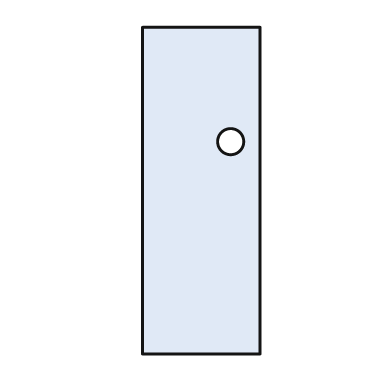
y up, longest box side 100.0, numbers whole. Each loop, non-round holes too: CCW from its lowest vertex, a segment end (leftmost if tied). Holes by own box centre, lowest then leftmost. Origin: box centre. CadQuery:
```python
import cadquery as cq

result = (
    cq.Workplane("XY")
    .moveTo(-18.0, -50.0)
    .lineTo(18.0, -50.0)
    .lineTo(18.0, 50.0)
    .lineTo(-18.0, 50.0)
    .close()
    .moveTo(9.0, 15.0)
    .circle(4.0)
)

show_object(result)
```